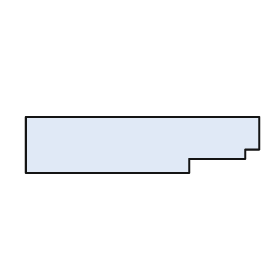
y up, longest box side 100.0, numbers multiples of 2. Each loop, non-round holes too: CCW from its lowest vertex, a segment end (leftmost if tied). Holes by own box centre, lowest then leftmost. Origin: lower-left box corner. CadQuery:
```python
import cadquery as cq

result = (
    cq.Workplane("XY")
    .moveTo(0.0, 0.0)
    .lineTo(70.0, 0.0)
    .lineTo(70.0, 6.0)
    .lineTo(94.0, 6.0)
    .lineTo(94.0, 10.0)
    .lineTo(100.0, 10.0)
    .lineTo(100.0, 24.0)
    .lineTo(0.0, 24.0)
    .close()
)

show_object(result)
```